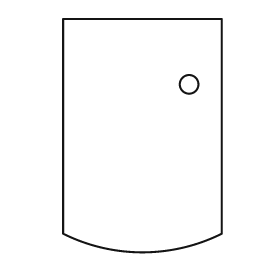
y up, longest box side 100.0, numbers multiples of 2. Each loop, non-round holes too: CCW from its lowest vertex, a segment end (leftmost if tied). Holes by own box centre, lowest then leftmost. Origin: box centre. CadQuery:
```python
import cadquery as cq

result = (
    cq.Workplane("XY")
    .moveTo(-34.0, -42.0)
    .threePointArc((0.0, -50.0), (34.0, -42.0))
    .lineTo(34.0, 50.0)
    .lineTo(-34.0, 50.0)
    .close()
    .moveTo(20.0, 22.0)
    .circle(4.0)
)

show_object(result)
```